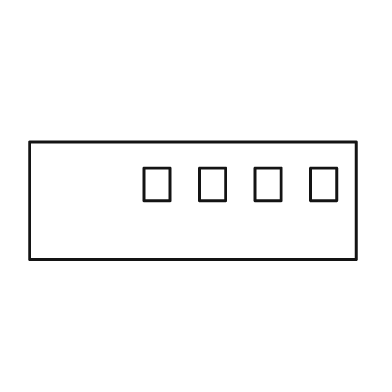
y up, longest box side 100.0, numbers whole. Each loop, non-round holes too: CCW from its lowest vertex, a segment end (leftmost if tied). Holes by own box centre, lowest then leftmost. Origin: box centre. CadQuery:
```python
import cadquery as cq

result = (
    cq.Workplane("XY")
    .moveTo(-50.0, -18.0)
    .lineTo(50.0, -18.0)
    .lineTo(50.0, 18.0)
    .lineTo(-50.0, 18.0)
    .close()
    .moveTo(-15.0, 0.0)
    .lineTo(-7.0, 0.0)
    .lineTo(-7.0, 10.0)
    .lineTo(-15.0, 10.0)
    .close()
    .moveTo(2.0, 0.0)
    .lineTo(10.0, 0.0)
    .lineTo(10.0, 10.0)
    .lineTo(2.0, 10.0)
    .close()
    .moveTo(19.0, 0.0)
    .lineTo(27.0, 0.0)
    .lineTo(27.0, 10.0)
    .lineTo(19.0, 10.0)
    .close()
    .moveTo(36.0, 0.0)
    .lineTo(44.0, 0.0)
    .lineTo(44.0, 10.0)
    .lineTo(36.0, 10.0)
    .close()
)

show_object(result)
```